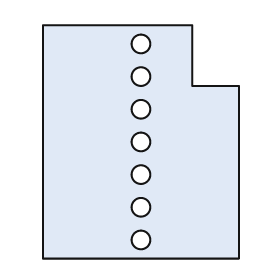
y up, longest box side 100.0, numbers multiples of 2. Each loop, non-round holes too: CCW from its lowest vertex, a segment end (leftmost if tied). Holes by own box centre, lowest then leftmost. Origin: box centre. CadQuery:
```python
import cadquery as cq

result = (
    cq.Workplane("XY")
    .moveTo(-42.0, -50.0)
    .lineTo(42.0, -50.0)
    .lineTo(42.0, 24.0)
    .lineTo(22.0, 24.0)
    .lineTo(22.0, 50.0)
    .lineTo(-42.0, 50.0)
    .close()
    .moveTo(0.0, -42.0)
    .circle(4.0)
    .moveTo(0.0, -28.0)
    .circle(4.0)
    .moveTo(0.0, -14.0)
    .circle(4.0)
    .moveTo(0.0, 0.0)
    .circle(4.0)
    .moveTo(0.0, 14.0)
    .circle(4.0)
    .moveTo(0.0, 28.0)
    .circle(4.0)
    .moveTo(0.0, 42.0)
    .circle(4.0)
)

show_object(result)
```